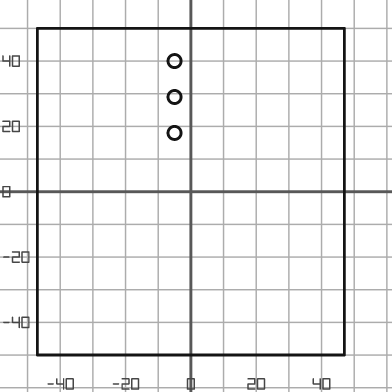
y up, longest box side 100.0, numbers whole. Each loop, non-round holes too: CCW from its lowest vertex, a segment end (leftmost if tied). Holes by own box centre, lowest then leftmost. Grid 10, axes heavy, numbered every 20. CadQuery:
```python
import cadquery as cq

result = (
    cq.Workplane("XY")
    .moveTo(-47.0, -50.0)
    .lineTo(47.0, -50.0)
    .lineTo(47.0, 50.0)
    .lineTo(-47.0, 50.0)
    .close()
    .moveTo(-5.0, 18.0)
    .circle(2.0)
    .moveTo(-5.0, 29.0)
    .circle(2.0)
    .moveTo(-5.0, 40.0)
    .circle(2.0)
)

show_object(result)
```